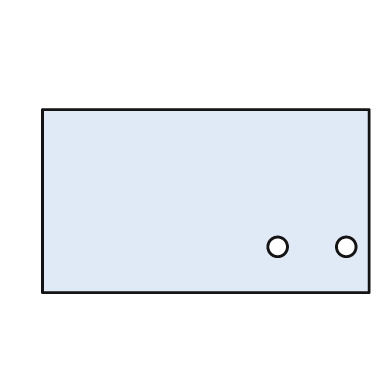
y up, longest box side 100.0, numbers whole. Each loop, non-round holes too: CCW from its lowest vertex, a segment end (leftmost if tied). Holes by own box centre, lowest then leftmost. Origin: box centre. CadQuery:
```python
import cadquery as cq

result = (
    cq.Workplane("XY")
    .moveTo(-50.0, -28.0)
    .lineTo(50.0, -28.0)
    .lineTo(50.0, 28.0)
    .lineTo(-50.0, 28.0)
    .close()
    .moveTo(22.0, -14.0)
    .circle(3.0)
    .moveTo(43.0, -14.0)
    .circle(3.0)
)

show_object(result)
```